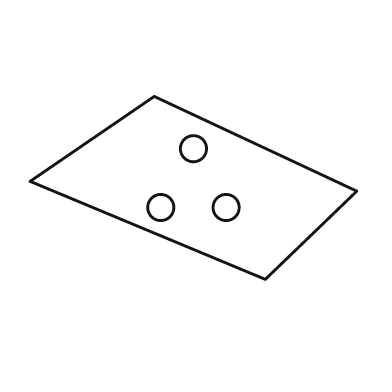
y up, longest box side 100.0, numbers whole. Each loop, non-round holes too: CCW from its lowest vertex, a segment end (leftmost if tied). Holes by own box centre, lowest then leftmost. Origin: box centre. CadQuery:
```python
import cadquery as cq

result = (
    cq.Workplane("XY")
    .moveTo(22.0, -28.0)
    .lineTo(50.0, -1.0)
    .lineTo(-12.0, 28.0)
    .lineTo(-50.0, 2.0)
    .close()
    .moveTo(-10.0, -6.0)
    .circle(4.0)
    .moveTo(10.0, -6.0)
    .circle(4.0)
    .moveTo(0.0, 12.0)
    .circle(4.0)
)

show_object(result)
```